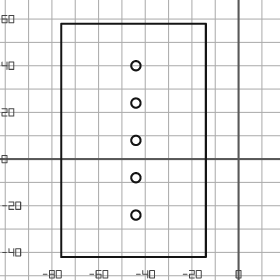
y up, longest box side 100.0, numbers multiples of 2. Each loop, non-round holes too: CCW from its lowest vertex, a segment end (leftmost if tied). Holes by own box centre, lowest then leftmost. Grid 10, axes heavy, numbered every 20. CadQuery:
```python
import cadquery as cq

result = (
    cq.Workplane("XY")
    .moveTo(-76.0, -42.0)
    .lineTo(-14.0, -42.0)
    .lineTo(-14.0, 58.0)
    .lineTo(-76.0, 58.0)
    .close()
    .moveTo(-44.0, -24.0)
    .circle(2.0)
    .moveTo(-44.0, -8.0)
    .circle(2.0)
    .moveTo(-44.0, 8.0)
    .circle(2.0)
    .moveTo(-44.0, 24.0)
    .circle(2.0)
    .moveTo(-44.0, 40.0)
    .circle(2.0)
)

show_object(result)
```